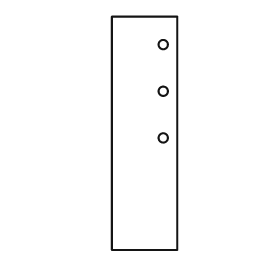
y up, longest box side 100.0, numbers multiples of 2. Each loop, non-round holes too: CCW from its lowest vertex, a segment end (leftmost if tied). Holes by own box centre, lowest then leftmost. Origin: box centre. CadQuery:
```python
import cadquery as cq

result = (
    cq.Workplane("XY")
    .moveTo(-14.0, -50.0)
    .lineTo(14.0, -50.0)
    .lineTo(14.0, 50.0)
    .lineTo(-14.0, 50.0)
    .close()
    .moveTo(8.0, -2.0)
    .circle(2.0)
    .moveTo(8.0, 18.0)
    .circle(2.0)
    .moveTo(8.0, 38.0)
    .circle(2.0)
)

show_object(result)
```